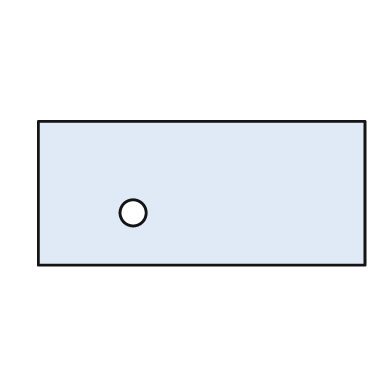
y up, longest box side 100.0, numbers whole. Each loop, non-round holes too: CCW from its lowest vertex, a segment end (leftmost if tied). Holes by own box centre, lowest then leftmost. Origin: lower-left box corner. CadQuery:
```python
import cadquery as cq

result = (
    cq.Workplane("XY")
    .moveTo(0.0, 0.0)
    .lineTo(100.0, 0.0)
    .lineTo(100.0, 44.0)
    .lineTo(0.0, 44.0)
    .close()
    .moveTo(29.0, 16.0)
    .circle(4.0)
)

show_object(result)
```